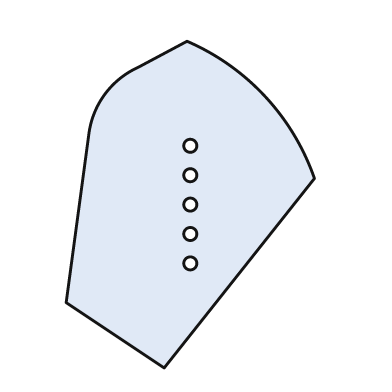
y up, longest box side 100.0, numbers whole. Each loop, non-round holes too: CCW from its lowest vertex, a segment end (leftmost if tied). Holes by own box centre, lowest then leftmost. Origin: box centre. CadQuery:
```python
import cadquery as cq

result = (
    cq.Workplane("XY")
    .moveTo(-8.0, -50.0)
    .lineTo(38.0, 8.0)
    .threePointArc((23.0, 33.0), (-1.0, 50.0))
    .lineTo(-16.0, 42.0)
    .threePointArc((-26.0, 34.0), (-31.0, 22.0))
    .lineTo(-38.0, -30.0)
    .close()
    .moveTo(0.0, -18.0)
    .circle(2.0)
    .moveTo(0.0, -9.0)
    .circle(2.0)
    .moveTo(0.0, 0.0)
    .circle(2.0)
    .moveTo(0.0, 9.0)
    .circle(2.0)
    .moveTo(0.0, 18.0)
    .circle(2.0)
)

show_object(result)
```